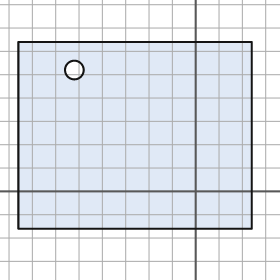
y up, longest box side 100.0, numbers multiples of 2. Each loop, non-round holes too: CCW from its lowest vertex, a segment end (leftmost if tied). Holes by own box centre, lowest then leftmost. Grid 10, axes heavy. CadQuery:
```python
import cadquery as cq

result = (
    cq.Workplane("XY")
    .moveTo(-76.0, -16.0)
    .lineTo(24.0, -16.0)
    .lineTo(24.0, 64.0)
    .lineTo(-76.0, 64.0)
    .close()
    .moveTo(-52.0, 52.0)
    .circle(4.0)
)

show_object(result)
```